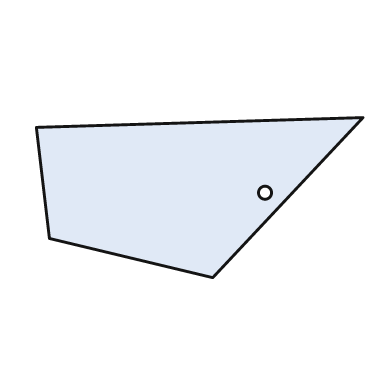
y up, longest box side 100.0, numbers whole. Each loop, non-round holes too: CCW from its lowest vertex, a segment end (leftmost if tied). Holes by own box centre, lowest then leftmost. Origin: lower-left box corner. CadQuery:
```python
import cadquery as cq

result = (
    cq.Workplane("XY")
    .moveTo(54.0, 0.0)
    .lineTo(100.0, 49.0)
    .lineTo(0.0, 46.0)
    .lineTo(4.0, 12.0)
    .close()
    .moveTo(70.0, 26.0)
    .circle(2.0)
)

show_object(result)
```